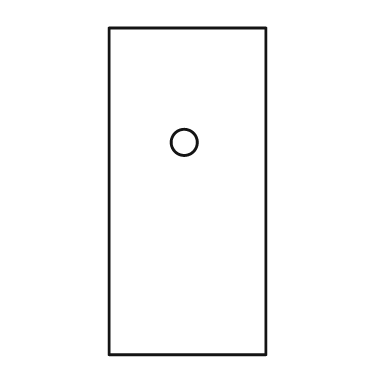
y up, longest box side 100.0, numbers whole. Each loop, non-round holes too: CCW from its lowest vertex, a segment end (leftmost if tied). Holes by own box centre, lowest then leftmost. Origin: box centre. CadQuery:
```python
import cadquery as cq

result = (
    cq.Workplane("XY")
    .moveTo(-24.0, -50.0)
    .lineTo(24.0, -50.0)
    .lineTo(24.0, 50.0)
    .lineTo(-24.0, 50.0)
    .close()
    .moveTo(-1.0, 15.0)
    .circle(4.0)
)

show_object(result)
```